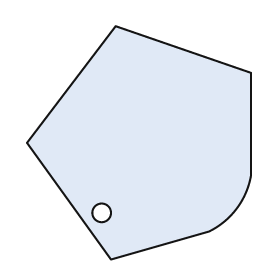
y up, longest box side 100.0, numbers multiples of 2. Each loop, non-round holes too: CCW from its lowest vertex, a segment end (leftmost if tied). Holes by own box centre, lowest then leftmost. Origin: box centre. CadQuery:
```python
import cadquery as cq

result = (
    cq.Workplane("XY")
    .moveTo(-12.0, -50.0)
    .lineTo(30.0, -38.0)
    .threePointArc((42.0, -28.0), (48.0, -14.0))
    .lineTo(48.0, 30.0)
    .lineTo(-10.0, 50.0)
    .lineTo(-48.0, 0.0)
    .close()
    .moveTo(-16.0, -30.0)
    .circle(4.0)
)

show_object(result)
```